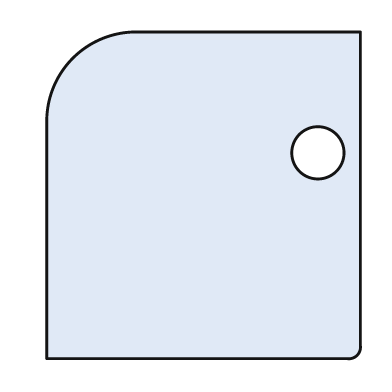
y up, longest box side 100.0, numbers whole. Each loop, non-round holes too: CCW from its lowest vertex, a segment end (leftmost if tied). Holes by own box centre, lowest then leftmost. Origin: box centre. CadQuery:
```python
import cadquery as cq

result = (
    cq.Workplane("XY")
    .moveTo(-48.0, -50.0)
    .lineTo(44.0, -50.0)
    .threePointArc((47.0, -49.0), (48.0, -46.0))
    .lineTo(48.0, 50.0)
    .lineTo(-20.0, 50.0)
    .threePointArc((-40.0, 42.0), (-48.0, 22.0))
    .close()
    .moveTo(35.0, 13.0)
    .circle(8.0)
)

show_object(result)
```